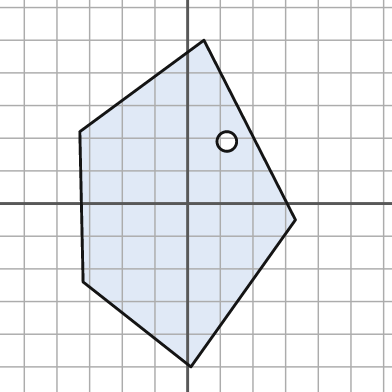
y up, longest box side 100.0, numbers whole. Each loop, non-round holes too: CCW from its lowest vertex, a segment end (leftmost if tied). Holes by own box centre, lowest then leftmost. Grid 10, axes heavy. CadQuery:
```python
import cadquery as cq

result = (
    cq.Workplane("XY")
    .moveTo(1.0, -50.0)
    .lineTo(33.0, -5.0)
    .lineTo(5.0, 50.0)
    .lineTo(-33.0, 22.0)
    .lineTo(-32.0, -24.0)
    .close()
    .moveTo(12.0, 19.0)
    .circle(3.0)
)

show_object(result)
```